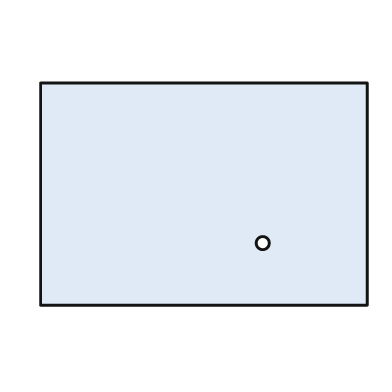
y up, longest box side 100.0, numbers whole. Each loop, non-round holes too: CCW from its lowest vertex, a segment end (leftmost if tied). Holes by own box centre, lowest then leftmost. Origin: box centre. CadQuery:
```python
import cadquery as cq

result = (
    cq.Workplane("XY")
    .moveTo(-50.0, -34.0)
    .lineTo(50.0, -34.0)
    .lineTo(50.0, 34.0)
    .lineTo(-50.0, 34.0)
    .close()
    .moveTo(18.0, -15.0)
    .circle(2.0)
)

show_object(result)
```